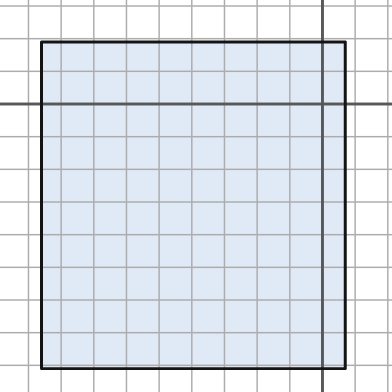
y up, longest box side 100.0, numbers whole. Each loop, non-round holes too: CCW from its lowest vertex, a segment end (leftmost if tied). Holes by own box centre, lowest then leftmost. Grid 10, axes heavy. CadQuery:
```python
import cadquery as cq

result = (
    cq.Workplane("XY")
    .moveTo(-86.0, -81.0)
    .lineTo(7.0, -81.0)
    .lineTo(7.0, 19.0)
    .lineTo(-86.0, 19.0)
    .close()
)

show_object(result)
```